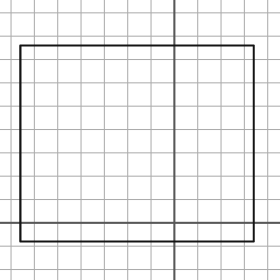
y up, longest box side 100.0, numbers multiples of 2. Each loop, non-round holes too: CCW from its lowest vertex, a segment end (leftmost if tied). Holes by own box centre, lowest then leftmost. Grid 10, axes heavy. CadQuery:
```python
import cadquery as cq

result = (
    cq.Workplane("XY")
    .moveTo(-66.0, -8.0)
    .lineTo(34.0, -8.0)
    .lineTo(34.0, 76.0)
    .lineTo(-66.0, 76.0)
    .close()
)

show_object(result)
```